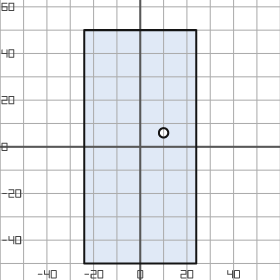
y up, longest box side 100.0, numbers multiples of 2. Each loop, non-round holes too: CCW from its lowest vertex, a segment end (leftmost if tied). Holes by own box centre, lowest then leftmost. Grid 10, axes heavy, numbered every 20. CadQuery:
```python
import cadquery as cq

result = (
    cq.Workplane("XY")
    .moveTo(-24.0, -50.0)
    .lineTo(24.0, -50.0)
    .lineTo(24.0, 50.0)
    .lineTo(-24.0, 50.0)
    .close()
    .moveTo(10.0, 6.0)
    .circle(2.0)
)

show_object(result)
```